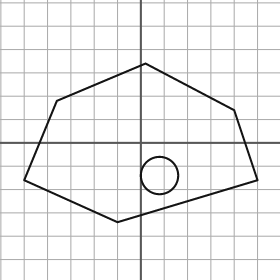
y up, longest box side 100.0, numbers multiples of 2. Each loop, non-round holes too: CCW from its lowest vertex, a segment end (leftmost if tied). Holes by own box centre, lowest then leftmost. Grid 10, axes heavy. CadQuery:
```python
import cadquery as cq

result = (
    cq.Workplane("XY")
    .moveTo(-10.0, -34.0)
    .lineTo(50.0, -16.0)
    .lineTo(40.0, 14.0)
    .lineTo(2.0, 34.0)
    .lineTo(-36.0, 18.0)
    .lineTo(-50.0, -16.0)
    .close()
    .moveTo(8.0, -14.0)
    .circle(8.0)
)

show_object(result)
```